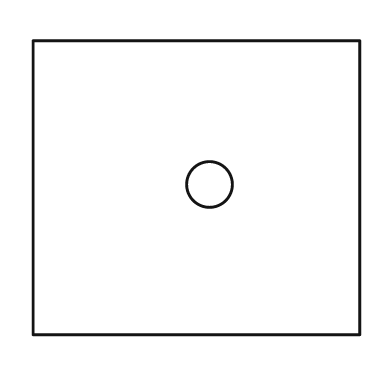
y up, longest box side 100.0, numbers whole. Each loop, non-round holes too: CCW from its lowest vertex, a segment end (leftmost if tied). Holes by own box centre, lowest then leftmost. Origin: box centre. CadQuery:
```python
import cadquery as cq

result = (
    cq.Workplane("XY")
    .moveTo(-50.0, -45.0)
    .lineTo(50.0, -45.0)
    .lineTo(50.0, 45.0)
    .lineTo(-50.0, 45.0)
    .close()
    .moveTo(4.0, 1.0)
    .circle(7.0)
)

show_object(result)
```